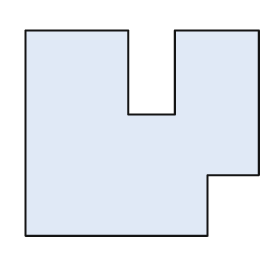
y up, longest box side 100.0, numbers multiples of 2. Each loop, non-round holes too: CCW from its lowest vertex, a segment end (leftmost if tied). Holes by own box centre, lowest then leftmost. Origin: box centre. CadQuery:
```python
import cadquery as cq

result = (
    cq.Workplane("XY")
    .moveTo(-50.0, -44.0)
    .lineTo(28.0, -44.0)
    .lineTo(28.0, -18.0)
    .lineTo(50.0, -18.0)
    .lineTo(50.0, 44.0)
    .lineTo(14.0, 44.0)
    .lineTo(14.0, 8.0)
    .lineTo(-6.0, 8.0)
    .lineTo(-6.0, 44.0)
    .lineTo(-50.0, 44.0)
    .close()
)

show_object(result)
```